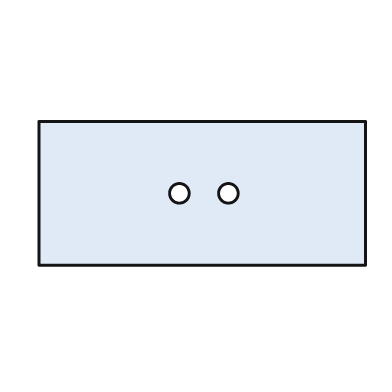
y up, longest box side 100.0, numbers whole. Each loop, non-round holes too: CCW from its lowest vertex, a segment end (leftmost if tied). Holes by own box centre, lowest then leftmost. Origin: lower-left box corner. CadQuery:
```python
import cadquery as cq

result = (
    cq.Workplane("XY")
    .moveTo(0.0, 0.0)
    .lineTo(100.0, 0.0)
    .lineTo(100.0, 44.0)
    .lineTo(0.0, 44.0)
    .close()
    .moveTo(43.0, 22.0)
    .circle(3.0)
    .moveTo(58.0, 22.0)
    .circle(3.0)
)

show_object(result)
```